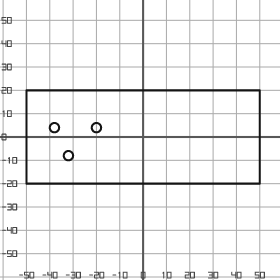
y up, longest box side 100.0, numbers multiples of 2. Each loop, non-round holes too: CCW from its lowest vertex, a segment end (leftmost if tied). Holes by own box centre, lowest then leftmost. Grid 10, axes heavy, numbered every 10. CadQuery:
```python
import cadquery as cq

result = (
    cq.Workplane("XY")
    .moveTo(-50.0, -20.0)
    .lineTo(50.0, -20.0)
    .lineTo(50.0, 20.0)
    .lineTo(-50.0, 20.0)
    .close()
    .moveTo(-32.0, -8.0)
    .circle(2.0)
    .moveTo(-38.0, 4.0)
    .circle(2.0)
    .moveTo(-20.0, 4.0)
    .circle(2.0)
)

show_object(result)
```